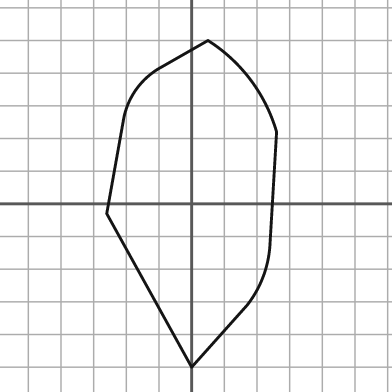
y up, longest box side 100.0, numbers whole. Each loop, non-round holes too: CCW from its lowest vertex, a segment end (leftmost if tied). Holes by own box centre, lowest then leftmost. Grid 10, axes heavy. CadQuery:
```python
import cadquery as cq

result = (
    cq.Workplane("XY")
    .moveTo(0.0, -50.0)
    .lineTo(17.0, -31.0)
    .threePointArc((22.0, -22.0), (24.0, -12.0))
    .lineTo(26.0, 22.0)
    .threePointArc((18.0, 38.0), (5.0, 50.0))
    .lineTo(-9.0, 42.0)
    .threePointArc((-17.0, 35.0), (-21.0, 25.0))
    .lineTo(-26.0, -3.0)
    .close()
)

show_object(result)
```